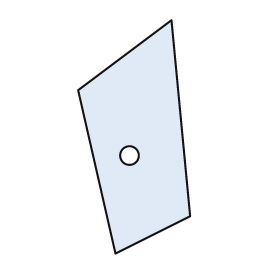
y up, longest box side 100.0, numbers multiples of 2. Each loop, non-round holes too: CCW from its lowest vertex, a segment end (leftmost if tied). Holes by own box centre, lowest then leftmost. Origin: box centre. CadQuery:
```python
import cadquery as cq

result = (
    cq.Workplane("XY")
    .moveTo(-8.0, -50.0)
    .lineTo(24.0, -34.0)
    .lineTo(16.0, 50.0)
    .lineTo(-24.0, 20.0)
    .close()
    .moveTo(-2.0, -8.0)
    .circle(4.0)
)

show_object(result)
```